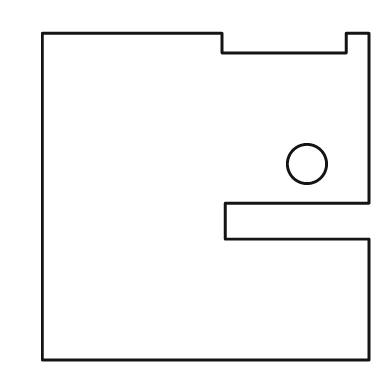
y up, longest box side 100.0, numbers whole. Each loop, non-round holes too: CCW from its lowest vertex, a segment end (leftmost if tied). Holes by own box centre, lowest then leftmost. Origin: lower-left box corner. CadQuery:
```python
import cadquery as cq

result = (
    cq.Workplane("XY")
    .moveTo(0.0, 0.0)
    .lineTo(100.0, 0.0)
    .lineTo(100.0, 37.0)
    .lineTo(56.0, 37.0)
    .lineTo(56.0, 48.0)
    .lineTo(100.0, 48.0)
    .lineTo(100.0, 100.0)
    .lineTo(93.0, 100.0)
    .lineTo(93.0, 94.0)
    .lineTo(55.0, 94.0)
    .lineTo(55.0, 100.0)
    .lineTo(0.0, 100.0)
    .close()
    .moveTo(81.0, 60.0)
    .circle(6.0)
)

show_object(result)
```